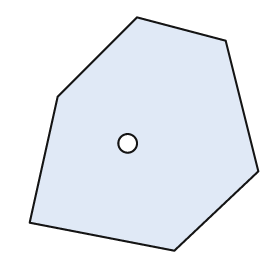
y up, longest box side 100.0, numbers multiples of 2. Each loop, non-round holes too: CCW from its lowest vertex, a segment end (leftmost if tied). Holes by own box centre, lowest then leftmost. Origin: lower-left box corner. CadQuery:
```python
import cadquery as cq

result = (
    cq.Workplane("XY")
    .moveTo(62.0, 0.0)
    .lineTo(98.0, 34.0)
    .lineTo(84.0, 90.0)
    .lineTo(46.0, 100.0)
    .lineTo(12.0, 66.0)
    .lineTo(0.0, 12.0)
    .close()
    .moveTo(42.0, 46.0)
    .circle(4.0)
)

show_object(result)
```